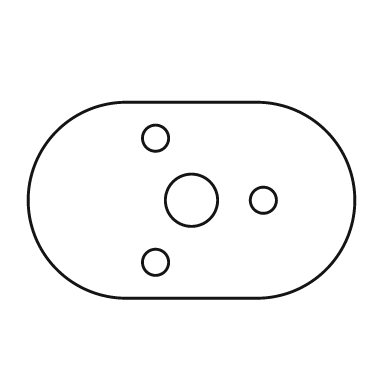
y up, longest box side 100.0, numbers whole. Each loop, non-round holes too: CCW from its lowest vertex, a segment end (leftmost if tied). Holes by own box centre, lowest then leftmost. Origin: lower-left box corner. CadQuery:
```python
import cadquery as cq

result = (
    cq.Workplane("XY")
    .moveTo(30.0, 0.0)
    .lineTo(70.0, 0.0)
    .threePointArc((100.0, 30.0), (70.0, 60.0))
    .lineTo(30.0, 60.0)
    .threePointArc((0.0, 30.0), (30.0, 0.0))
    .close()
    .moveTo(39.0, 11.0)
    .circle(4.0)
    .moveTo(50.0, 30.0)
    .circle(8.0)
    .moveTo(72.0, 30.0)
    .circle(4.0)
    .moveTo(39.0, 49.0)
    .circle(4.0)
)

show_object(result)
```